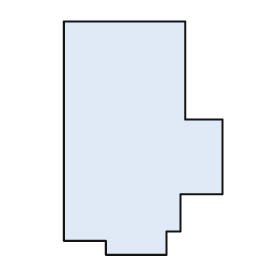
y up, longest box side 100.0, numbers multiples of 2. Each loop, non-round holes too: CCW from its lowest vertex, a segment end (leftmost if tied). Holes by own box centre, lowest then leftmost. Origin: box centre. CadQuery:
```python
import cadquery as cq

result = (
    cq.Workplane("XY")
    .moveTo(-16.0, -50.0)
    .lineTo(10.0, -50.0)
    .lineTo(10.0, -40.0)
    .lineTo(16.0, -40.0)
    .lineTo(16.0, -24.0)
    .lineTo(34.0, -24.0)
    .lineTo(34.0, 8.0)
    .lineTo(18.0, 8.0)
    .lineTo(18.0, 50.0)
    .lineTo(-34.0, 50.0)
    .lineTo(-34.0, -44.0)
    .lineTo(-16.0, -44.0)
    .close()
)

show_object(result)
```